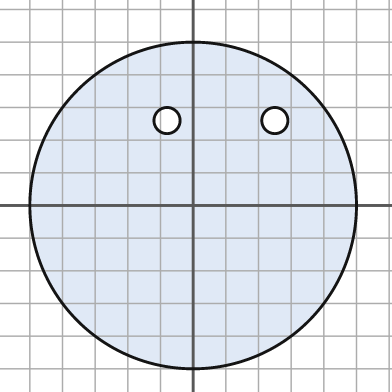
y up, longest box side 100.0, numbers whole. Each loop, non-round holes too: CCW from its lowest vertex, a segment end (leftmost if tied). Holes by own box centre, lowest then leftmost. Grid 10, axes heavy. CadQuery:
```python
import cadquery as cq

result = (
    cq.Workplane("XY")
    .moveTo(0.0, 0.0)
    .circle(50.0)
    .moveTo(-8.0, 26.0)
    .circle(4.0)
    .moveTo(25.0, 26.0)
    .circle(4.0)
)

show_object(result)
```